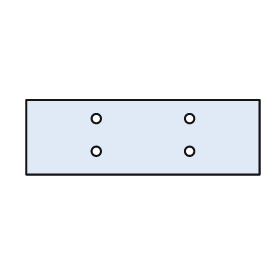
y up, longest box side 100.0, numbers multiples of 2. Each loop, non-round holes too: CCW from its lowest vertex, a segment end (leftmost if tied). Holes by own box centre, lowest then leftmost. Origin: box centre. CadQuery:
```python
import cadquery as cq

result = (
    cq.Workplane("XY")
    .moveTo(-50.0, -16.0)
    .lineTo(50.0, -16.0)
    .lineTo(50.0, 16.0)
    .lineTo(-50.0, 16.0)
    .close()
    .moveTo(-20.0, -6.0)
    .circle(2.0)
    .moveTo(20.0, -6.0)
    .circle(2.0)
    .moveTo(-20.0, 8.0)
    .circle(2.0)
    .moveTo(20.0, 8.0)
    .circle(2.0)
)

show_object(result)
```